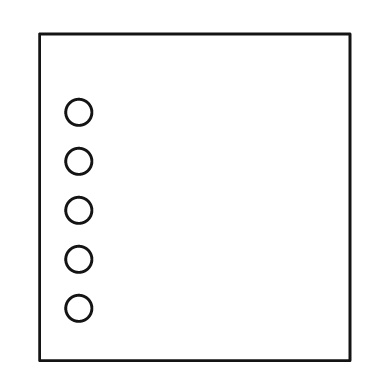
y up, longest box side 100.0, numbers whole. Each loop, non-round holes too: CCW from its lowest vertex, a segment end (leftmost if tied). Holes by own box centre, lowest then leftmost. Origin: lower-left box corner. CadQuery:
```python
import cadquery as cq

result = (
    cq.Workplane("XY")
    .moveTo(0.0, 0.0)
    .lineTo(95.0, 0.0)
    .lineTo(95.0, 100.0)
    .lineTo(0.0, 100.0)
    .close()
    .moveTo(12.0, 16.0)
    .circle(4.0)
    .moveTo(12.0, 31.0)
    .circle(4.0)
    .moveTo(12.0, 46.0)
    .circle(4.0)
    .moveTo(12.0, 61.0)
    .circle(4.0)
    .moveTo(12.0, 76.0)
    .circle(4.0)
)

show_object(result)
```